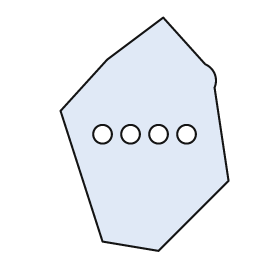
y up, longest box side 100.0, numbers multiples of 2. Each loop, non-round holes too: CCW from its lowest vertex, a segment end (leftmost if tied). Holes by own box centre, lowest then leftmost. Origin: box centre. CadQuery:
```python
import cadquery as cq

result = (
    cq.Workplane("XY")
    .moveTo(6.0, -50.0)
    .lineTo(36.0, -20.0)
    .lineTo(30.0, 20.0)
    .threePointArc((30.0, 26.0), (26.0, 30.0))
    .lineTo(8.0, 50.0)
    .lineTo(-16.0, 32.0)
    .lineTo(-36.0, 10.0)
    .lineTo(-18.0, -46.0)
    .close()
    .moveTo(-18.0, 0.0)
    .circle(4.0)
    .moveTo(-6.0, 0.0)
    .circle(4.0)
    .moveTo(6.0, 0.0)
    .circle(4.0)
    .moveTo(18.0, 0.0)
    .circle(4.0)
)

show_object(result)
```